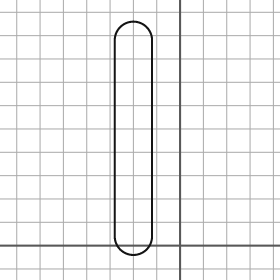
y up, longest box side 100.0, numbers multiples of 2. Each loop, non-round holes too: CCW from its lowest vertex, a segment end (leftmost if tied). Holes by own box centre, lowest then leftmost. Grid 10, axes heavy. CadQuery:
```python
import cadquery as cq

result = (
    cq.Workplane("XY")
    .moveTo(-28.0, 4.0)
    .threePointArc((-20.0, -4.0), (-12.0, 4.0))
    .lineTo(-12.0, 88.0)
    .threePointArc((-20.0, 96.0), (-28.0, 88.0))
    .close()
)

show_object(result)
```